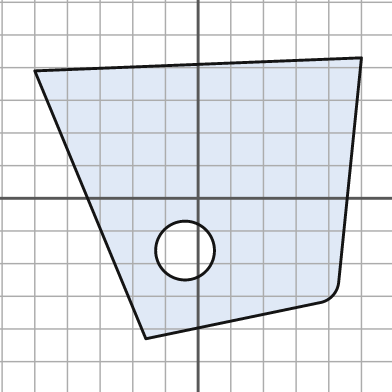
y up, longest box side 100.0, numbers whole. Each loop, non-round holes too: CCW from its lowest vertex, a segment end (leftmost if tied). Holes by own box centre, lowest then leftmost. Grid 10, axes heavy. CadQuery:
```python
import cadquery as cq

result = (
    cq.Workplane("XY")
    .moveTo(-16.0, -43.0)
    .lineTo(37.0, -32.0)
    .threePointArc((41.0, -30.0), (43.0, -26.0))
    .lineTo(50.0, 43.0)
    .lineTo(-50.0, 39.0)
    .close()
    .moveTo(-4.0, -16.0)
    .circle(9.0)
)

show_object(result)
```